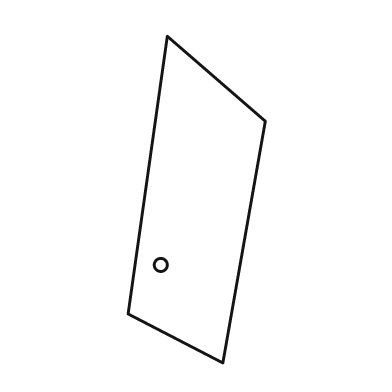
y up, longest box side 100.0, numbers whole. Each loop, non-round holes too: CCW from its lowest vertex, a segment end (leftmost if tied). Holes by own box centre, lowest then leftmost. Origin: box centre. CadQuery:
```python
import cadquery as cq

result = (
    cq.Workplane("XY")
    .moveTo(8.0, -50.0)
    .lineTo(21.0, 24.0)
    .lineTo(-9.0, 50.0)
    .lineTo(-21.0, -35.0)
    .close()
    .moveTo(-11.0, -20.0)
    .circle(2.0)
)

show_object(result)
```